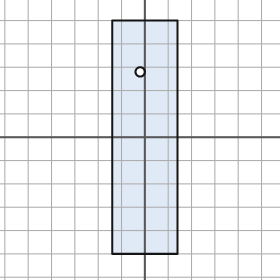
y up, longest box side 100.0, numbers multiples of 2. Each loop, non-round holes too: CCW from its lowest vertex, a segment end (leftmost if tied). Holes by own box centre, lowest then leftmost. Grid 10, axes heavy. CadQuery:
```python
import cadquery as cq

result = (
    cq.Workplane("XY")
    .moveTo(-14.0, -50.0)
    .lineTo(14.0, -50.0)
    .lineTo(14.0, 50.0)
    .lineTo(-14.0, 50.0)
    .close()
    .moveTo(-2.0, 28.0)
    .circle(2.0)
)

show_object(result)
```